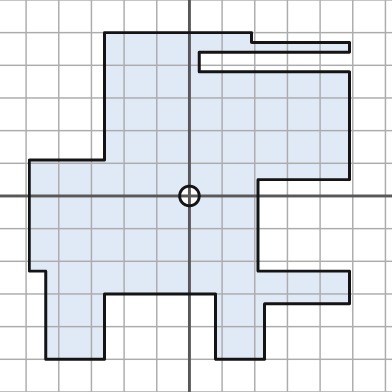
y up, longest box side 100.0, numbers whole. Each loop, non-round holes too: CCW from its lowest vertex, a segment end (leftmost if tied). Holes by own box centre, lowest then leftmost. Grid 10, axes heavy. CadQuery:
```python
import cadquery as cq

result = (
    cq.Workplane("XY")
    .moveTo(-44.0, -50.0)
    .lineTo(-26.0, -50.0)
    .lineTo(-26.0, -30.0)
    .lineTo(8.0, -30.0)
    .lineTo(8.0, -50.0)
    .lineTo(23.0, -50.0)
    .lineTo(23.0, -33.0)
    .lineTo(49.0, -33.0)
    .lineTo(49.0, -23.0)
    .lineTo(21.0, -23.0)
    .lineTo(21.0, 5.0)
    .lineTo(49.0, 5.0)
    .lineTo(49.0, 38.0)
    .lineTo(3.0, 38.0)
    .lineTo(3.0, 44.0)
    .lineTo(49.0, 44.0)
    .lineTo(49.0, 47.0)
    .lineTo(19.0, 47.0)
    .lineTo(19.0, 50.0)
    .lineTo(-26.0, 50.0)
    .lineTo(-26.0, 11.0)
    .lineTo(-49.0, 11.0)
    .lineTo(-49.0, -23.0)
    .lineTo(-44.0, -23.0)
    .close()
    .moveTo(0.0, 0.0)
    .circle(3.0)
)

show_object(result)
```